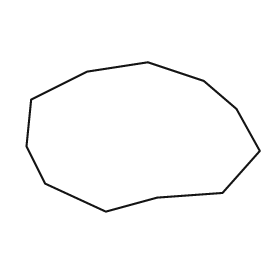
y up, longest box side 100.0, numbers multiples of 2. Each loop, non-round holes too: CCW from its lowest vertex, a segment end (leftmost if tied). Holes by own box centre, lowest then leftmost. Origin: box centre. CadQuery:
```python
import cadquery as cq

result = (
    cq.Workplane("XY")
    .moveTo(-16.0, -32.0)
    .lineTo(6.0, -26.0)
    .lineTo(34.0, -24.0)
    .lineTo(50.0, -6.0)
    .lineTo(40.0, 12.0)
    .lineTo(26.0, 24.0)
    .lineTo(2.0, 32.0)
    .lineTo(-24.0, 28.0)
    .lineTo(-48.0, 16.0)
    .lineTo(-50.0, -4.0)
    .lineTo(-42.0, -20.0)
    .close()
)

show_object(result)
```